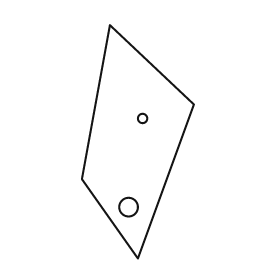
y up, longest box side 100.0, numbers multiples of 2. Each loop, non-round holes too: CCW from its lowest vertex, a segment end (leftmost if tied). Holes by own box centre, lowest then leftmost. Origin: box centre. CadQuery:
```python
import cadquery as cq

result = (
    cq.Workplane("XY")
    .moveTo(0.0, -50.0)
    .lineTo(24.0, 16.0)
    .lineTo(-12.0, 50.0)
    .lineTo(-24.0, -16.0)
    .close()
    .moveTo(-4.0, -28.0)
    .circle(4.0)
    .moveTo(2.0, 10.0)
    .circle(2.0)
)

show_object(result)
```